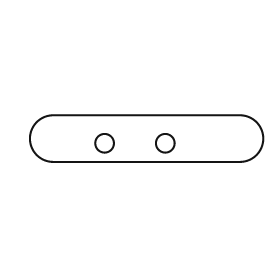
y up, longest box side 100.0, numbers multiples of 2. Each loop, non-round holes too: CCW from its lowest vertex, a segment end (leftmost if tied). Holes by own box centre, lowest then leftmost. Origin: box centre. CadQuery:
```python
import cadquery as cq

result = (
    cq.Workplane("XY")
    .moveTo(-40.0, -10.0)
    .lineTo(40.0, -10.0)
    .threePointArc((50.0, 0.0), (40.0, 10.0))
    .lineTo(-40.0, 10.0)
    .threePointArc((-50.0, 0.0), (-40.0, -10.0))
    .close()
    .moveTo(-18.0, -2.0)
    .circle(4.0)
    .moveTo(8.0, -2.0)
    .circle(4.0)
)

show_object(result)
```